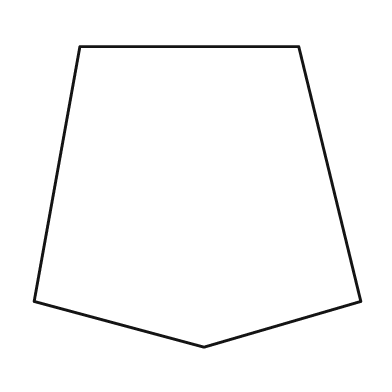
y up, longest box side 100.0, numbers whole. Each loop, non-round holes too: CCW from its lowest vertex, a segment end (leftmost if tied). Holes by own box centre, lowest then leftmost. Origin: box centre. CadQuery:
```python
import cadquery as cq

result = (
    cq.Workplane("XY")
    .moveTo(2.0, -46.0)
    .lineTo(50.0, -32.0)
    .lineTo(31.0, 46.0)
    .lineTo(-36.0, 46.0)
    .lineTo(-50.0, -32.0)
    .close()
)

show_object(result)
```